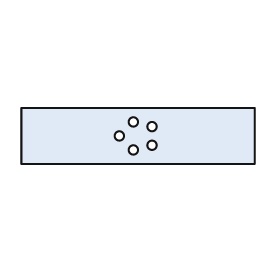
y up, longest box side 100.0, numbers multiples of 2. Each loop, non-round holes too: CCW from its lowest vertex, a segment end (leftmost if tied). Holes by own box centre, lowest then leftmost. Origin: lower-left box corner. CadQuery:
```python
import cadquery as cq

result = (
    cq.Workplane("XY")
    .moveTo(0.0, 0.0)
    .lineTo(100.0, 0.0)
    .lineTo(100.0, 24.0)
    .lineTo(0.0, 24.0)
    .close()
    .moveTo(48.0, 6.0)
    .circle(2.0)
    .moveTo(56.0, 8.0)
    .circle(2.0)
    .moveTo(42.0, 12.0)
    .circle(2.0)
    .moveTo(56.0, 16.0)
    .circle(2.0)
    .moveTo(48.0, 18.0)
    .circle(2.0)
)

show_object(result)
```